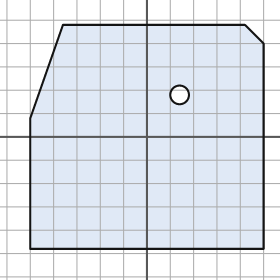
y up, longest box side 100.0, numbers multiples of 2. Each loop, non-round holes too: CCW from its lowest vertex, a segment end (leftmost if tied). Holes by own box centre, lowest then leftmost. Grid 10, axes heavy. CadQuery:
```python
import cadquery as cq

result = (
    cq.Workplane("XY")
    .moveTo(-50.0, -48.0)
    .lineTo(50.0, -48.0)
    .lineTo(50.0, 40.0)
    .lineTo(42.0, 48.0)
    .lineTo(-36.0, 48.0)
    .lineTo(-50.0, 8.0)
    .close()
    .moveTo(14.0, 18.0)
    .circle(4.0)
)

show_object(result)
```